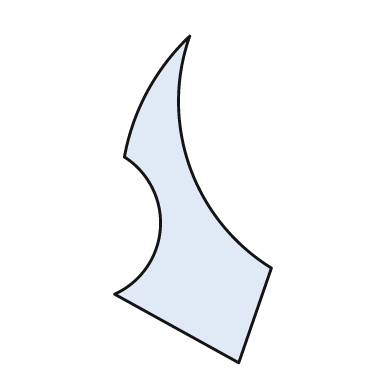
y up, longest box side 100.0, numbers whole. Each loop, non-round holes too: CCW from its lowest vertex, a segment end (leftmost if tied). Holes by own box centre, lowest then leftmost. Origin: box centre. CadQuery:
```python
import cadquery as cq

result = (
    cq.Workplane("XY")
    .moveTo(14.0, -50.0)
    .lineTo(24.0, -21.0)
    .threePointArc((-1.0, 10.0), (-1.0, 50.0))
    .threePointArc((-14.0, 33.0), (-21.0, 13.0))
    .threePointArc((-10.0, -9.0), (-24.0, -29.0))
    .close()
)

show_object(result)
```